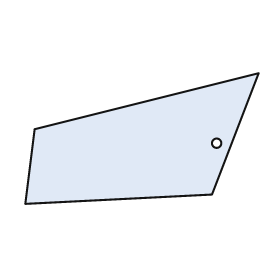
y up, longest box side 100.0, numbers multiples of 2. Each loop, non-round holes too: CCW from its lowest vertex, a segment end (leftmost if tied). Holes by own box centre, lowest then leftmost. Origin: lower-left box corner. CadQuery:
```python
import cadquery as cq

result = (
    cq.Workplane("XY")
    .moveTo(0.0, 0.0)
    .lineTo(80.0, 4.0)
    .lineTo(100.0, 56.0)
    .lineTo(4.0, 32.0)
    .close()
    .moveTo(82.0, 26.0)
    .circle(2.0)
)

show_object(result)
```